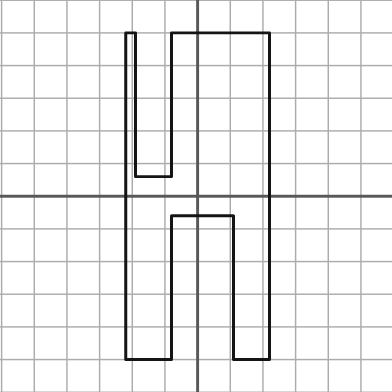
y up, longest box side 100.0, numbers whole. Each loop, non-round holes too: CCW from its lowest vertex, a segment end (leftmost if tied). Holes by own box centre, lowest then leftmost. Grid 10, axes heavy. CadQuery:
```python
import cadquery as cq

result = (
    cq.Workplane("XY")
    .moveTo(-22.0, -50.0)
    .lineTo(-8.0, -50.0)
    .lineTo(-8.0, -6.0)
    .lineTo(11.0, -6.0)
    .lineTo(11.0, -50.0)
    .lineTo(22.0, -50.0)
    .lineTo(22.0, 50.0)
    .lineTo(-8.0, 50.0)
    .lineTo(-8.0, 6.0)
    .lineTo(-19.0, 6.0)
    .lineTo(-19.0, 50.0)
    .lineTo(-22.0, 50.0)
    .close()
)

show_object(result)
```